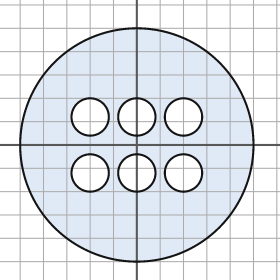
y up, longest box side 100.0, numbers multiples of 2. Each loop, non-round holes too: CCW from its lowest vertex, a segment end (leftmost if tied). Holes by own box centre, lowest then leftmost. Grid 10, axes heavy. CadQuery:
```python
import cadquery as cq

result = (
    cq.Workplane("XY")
    .moveTo(0.0, 0.0)
    .circle(50.0)
    .moveTo(-20.0, -12.0)
    .circle(8.0)
    .moveTo(0.0, -12.0)
    .circle(8.0)
    .moveTo(20.0, -12.0)
    .circle(8.0)
    .moveTo(-20.0, 12.0)
    .circle(8.0)
    .moveTo(0.0, 12.0)
    .circle(8.0)
    .moveTo(20.0, 12.0)
    .circle(8.0)
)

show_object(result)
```